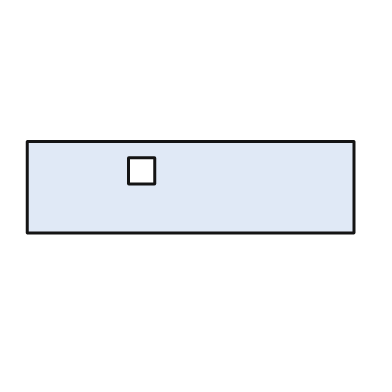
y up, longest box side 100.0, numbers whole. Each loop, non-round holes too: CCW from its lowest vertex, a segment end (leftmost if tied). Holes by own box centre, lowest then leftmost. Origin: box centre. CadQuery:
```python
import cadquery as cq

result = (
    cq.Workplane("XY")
    .moveTo(-50.0, -14.0)
    .lineTo(50.0, -14.0)
    .lineTo(50.0, 14.0)
    .lineTo(-50.0, 14.0)
    .close()
    .moveTo(-19.0, 1.0)
    .lineTo(-11.0, 1.0)
    .lineTo(-11.0, 9.0)
    .lineTo(-19.0, 9.0)
    .close()
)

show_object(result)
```